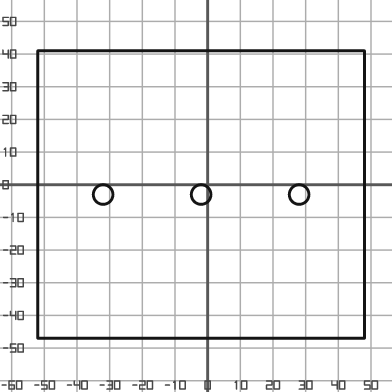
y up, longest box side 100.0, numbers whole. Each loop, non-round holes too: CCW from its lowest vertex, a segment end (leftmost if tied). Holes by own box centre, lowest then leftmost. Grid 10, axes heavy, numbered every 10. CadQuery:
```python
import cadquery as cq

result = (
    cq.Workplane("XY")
    .moveTo(-52.0, -47.0)
    .lineTo(48.0, -47.0)
    .lineTo(48.0, 41.0)
    .lineTo(-52.0, 41.0)
    .close()
    .moveTo(-32.0, -3.0)
    .circle(3.0)
    .moveTo(-2.0, -3.0)
    .circle(3.0)
    .moveTo(28.0, -3.0)
    .circle(3.0)
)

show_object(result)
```